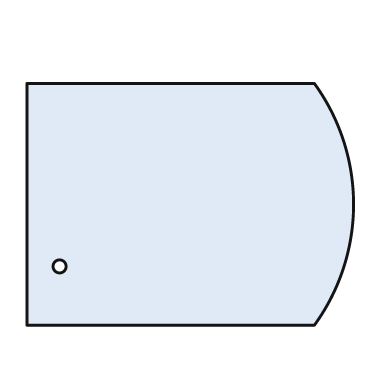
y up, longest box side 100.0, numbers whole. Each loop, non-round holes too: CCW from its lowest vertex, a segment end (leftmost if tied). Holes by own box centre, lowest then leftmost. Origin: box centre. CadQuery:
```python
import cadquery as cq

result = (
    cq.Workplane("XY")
    .moveTo(-50.0, -37.0)
    .lineTo(38.0, -37.0)
    .threePointArc((50.0, 0.0), (38.0, 37.0))
    .lineTo(-50.0, 37.0)
    .close()
    .moveTo(-40.0, -19.0)
    .circle(2.0)
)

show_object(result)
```